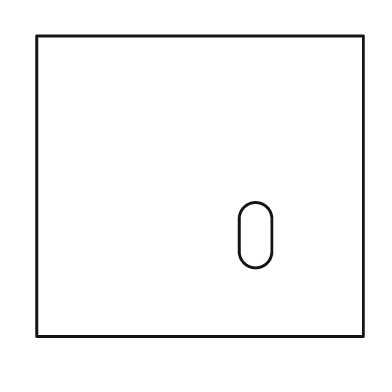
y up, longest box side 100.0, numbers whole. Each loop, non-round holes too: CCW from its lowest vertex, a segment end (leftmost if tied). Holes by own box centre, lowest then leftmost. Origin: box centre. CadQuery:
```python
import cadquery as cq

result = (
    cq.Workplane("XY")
    .moveTo(-50.0, -46.0)
    .lineTo(50.0, -46.0)
    .lineTo(50.0, 46.0)
    .lineTo(-50.0, 46.0)
    .close()
    .moveTo(12.0, -20.0)
    .threePointArc((17.0, -25.0), (22.0, -20.0))
    .lineTo(22.0, -10.0)
    .threePointArc((17.0, -5.0), (12.0, -10.0))
    .close()
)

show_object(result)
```